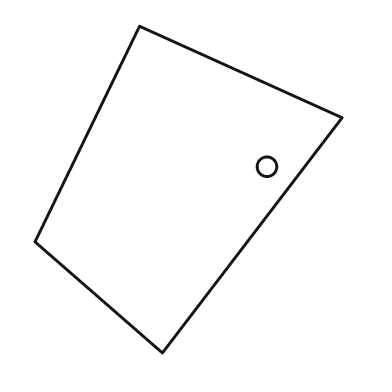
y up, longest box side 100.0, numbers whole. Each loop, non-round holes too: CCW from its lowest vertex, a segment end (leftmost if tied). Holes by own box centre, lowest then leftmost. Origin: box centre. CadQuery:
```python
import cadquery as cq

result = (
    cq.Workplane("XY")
    .moveTo(-8.0, -50.0)
    .lineTo(47.0, 22.0)
    .lineTo(-15.0, 50.0)
    .lineTo(-47.0, -16.0)
    .close()
    .moveTo(24.0, 7.0)
    .circle(3.0)
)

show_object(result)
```